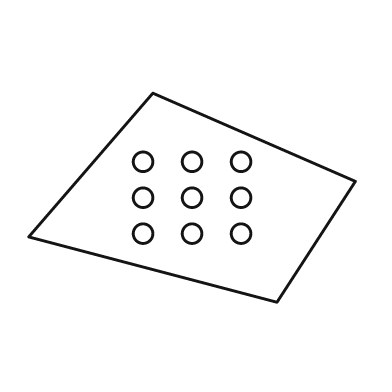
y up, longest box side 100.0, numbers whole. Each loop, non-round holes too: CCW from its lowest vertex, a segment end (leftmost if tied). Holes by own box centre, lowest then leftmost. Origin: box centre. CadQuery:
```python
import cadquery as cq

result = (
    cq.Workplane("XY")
    .moveTo(26.0, -32.0)
    .lineTo(50.0, 5.0)
    .lineTo(-12.0, 32.0)
    .lineTo(-50.0, -12.0)
    .close()
    .moveTo(-15.0, -11.0)
    .circle(3.0)
    .moveTo(0.0, -11.0)
    .circle(3.0)
    .moveTo(15.0, -11.0)
    .circle(3.0)
    .moveTo(-15.0, 0.0)
    .circle(3.0)
    .moveTo(0.0, 0.0)
    .circle(3.0)
    .moveTo(15.0, 0.0)
    .circle(3.0)
    .moveTo(-15.0, 11.0)
    .circle(3.0)
    .moveTo(0.0, 11.0)
    .circle(3.0)
    .moveTo(15.0, 11.0)
    .circle(3.0)
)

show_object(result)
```